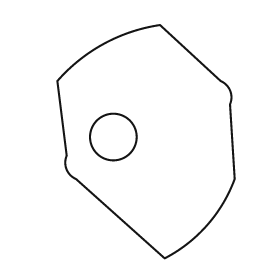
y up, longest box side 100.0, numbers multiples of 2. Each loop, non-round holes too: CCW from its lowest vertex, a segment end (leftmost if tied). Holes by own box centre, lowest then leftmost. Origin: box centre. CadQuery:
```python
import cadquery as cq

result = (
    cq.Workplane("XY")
    .moveTo(8.0, -50.0)
    .threePointArc((26.0, -36.0), (38.0, -16.0))
    .lineTo(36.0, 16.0)
    .threePointArc((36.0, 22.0), (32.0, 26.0))
    .lineTo(6.0, 50.0)
    .threePointArc((-18.0, 42.0), (-38.0, 26.0))
    .lineTo(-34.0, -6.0)
    .threePointArc((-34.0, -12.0), (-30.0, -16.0))
    .close()
    .moveTo(-14.0, 2.0)
    .circle(10.0)
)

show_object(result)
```